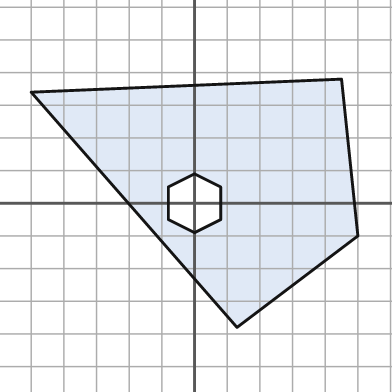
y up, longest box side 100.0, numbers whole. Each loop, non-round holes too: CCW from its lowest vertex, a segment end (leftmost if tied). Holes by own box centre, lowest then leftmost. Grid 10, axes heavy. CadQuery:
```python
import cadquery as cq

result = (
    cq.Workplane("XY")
    .moveTo(13.0, -38.0)
    .lineTo(50.0, -10.0)
    .lineTo(45.0, 38.0)
    .lineTo(-50.0, 34.0)
    .close()
    .moveTo(0.0, -9.0)
    .lineTo(8.0, -5.0)
    .lineTo(8.0, 5.0)
    .lineTo(0.0, 9.0)
    .lineTo(-8.0, 5.0)
    .lineTo(-8.0, -5.0)
    .close()
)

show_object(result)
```